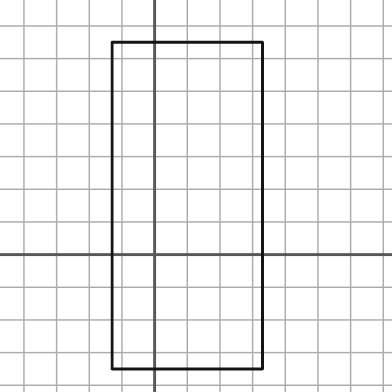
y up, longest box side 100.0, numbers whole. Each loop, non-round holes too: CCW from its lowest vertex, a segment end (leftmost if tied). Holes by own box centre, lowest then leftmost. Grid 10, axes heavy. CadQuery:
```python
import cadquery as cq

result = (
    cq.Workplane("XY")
    .moveTo(-13.0, -35.0)
    .lineTo(33.0, -35.0)
    .lineTo(33.0, 65.0)
    .lineTo(-13.0, 65.0)
    .close()
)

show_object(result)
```